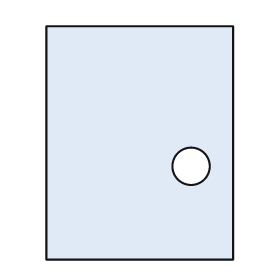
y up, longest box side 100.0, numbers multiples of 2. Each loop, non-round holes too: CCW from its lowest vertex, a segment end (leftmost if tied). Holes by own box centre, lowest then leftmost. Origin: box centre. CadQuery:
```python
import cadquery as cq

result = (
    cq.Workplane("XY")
    .moveTo(-40.0, -50.0)
    .lineTo(40.0, -50.0)
    .lineTo(40.0, 50.0)
    .lineTo(-40.0, 50.0)
    .close()
    .moveTo(22.0, -10.0)
    .circle(8.0)
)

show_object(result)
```